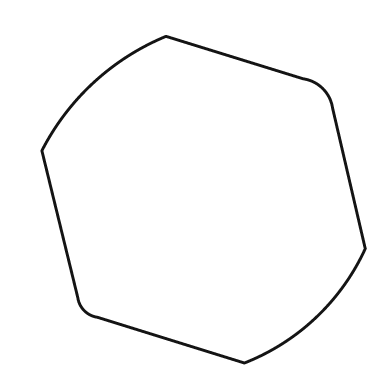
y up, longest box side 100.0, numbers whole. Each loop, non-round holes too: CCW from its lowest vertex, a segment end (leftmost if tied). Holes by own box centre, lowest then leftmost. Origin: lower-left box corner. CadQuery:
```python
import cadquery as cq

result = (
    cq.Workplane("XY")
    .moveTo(62.0, 0.0)
    .threePointArc((84.0, 14.0), (99.0, 35.0))
    .lineTo(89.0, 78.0)
    .threePointArc((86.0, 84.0), (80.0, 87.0))
    .lineTo(38.0, 100.0)
    .threePointArc((16.0, 86.0), (0.0, 65.0))
    .lineTo(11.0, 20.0)
    .threePointArc((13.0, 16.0), (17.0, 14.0))
    .close()
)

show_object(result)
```